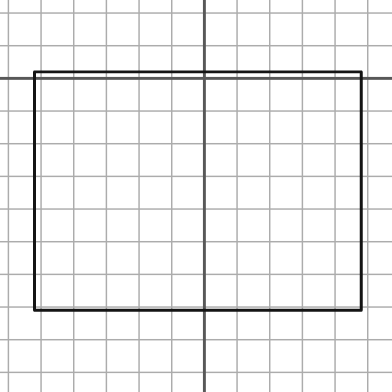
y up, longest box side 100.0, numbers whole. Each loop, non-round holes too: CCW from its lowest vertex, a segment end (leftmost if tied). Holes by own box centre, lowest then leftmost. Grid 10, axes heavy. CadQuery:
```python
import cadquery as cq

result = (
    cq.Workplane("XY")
    .moveTo(-52.0, -71.0)
    .lineTo(48.0, -71.0)
    .lineTo(48.0, 2.0)
    .lineTo(-52.0, 2.0)
    .close()
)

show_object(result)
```